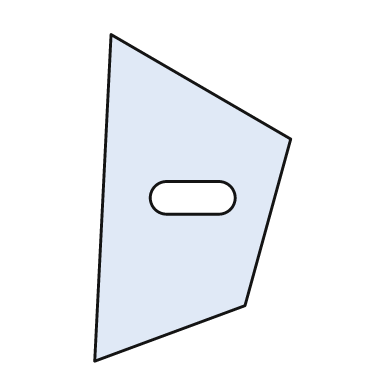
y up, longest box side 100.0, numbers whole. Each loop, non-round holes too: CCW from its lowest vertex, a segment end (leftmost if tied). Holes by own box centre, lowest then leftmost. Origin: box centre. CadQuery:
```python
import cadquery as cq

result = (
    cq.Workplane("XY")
    .moveTo(-30.0, -50.0)
    .lineTo(16.0, -33.0)
    .lineTo(30.0, 18.0)
    .lineTo(-25.0, 50.0)
    .close()
    .moveTo(-8.0, -5.0)
    .lineTo(8.0, -5.0)
    .threePointArc((13.0, 0.0), (8.0, 5.0))
    .lineTo(-8.0, 5.0)
    .threePointArc((-13.0, 0.0), (-8.0, -5.0))
    .close()
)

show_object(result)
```